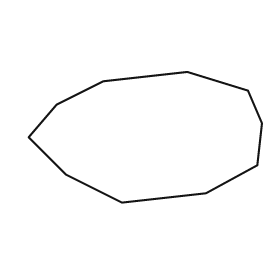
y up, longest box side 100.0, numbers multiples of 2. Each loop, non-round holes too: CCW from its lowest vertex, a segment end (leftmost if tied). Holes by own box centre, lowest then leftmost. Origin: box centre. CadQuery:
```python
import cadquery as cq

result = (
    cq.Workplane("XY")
    .moveTo(-10.0, -28.0)
    .lineTo(26.0, -24.0)
    .lineTo(48.0, -12.0)
    .lineTo(50.0, 6.0)
    .lineTo(44.0, 20.0)
    .lineTo(18.0, 28.0)
    .lineTo(-18.0, 24.0)
    .lineTo(-38.0, 14.0)
    .lineTo(-50.0, 0.0)
    .lineTo(-34.0, -16.0)
    .close()
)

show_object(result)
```